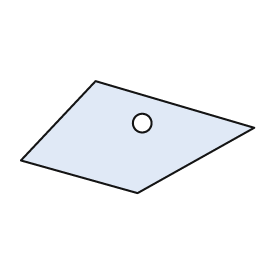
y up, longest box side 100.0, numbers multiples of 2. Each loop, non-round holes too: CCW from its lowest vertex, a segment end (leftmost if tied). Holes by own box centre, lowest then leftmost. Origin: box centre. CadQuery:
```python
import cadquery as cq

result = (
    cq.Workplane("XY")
    .moveTo(0.0, -24.0)
    .lineTo(50.0, 4.0)
    .lineTo(-18.0, 24.0)
    .lineTo(-50.0, -10.0)
    .close()
    .moveTo(2.0, 6.0)
    .circle(4.0)
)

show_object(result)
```